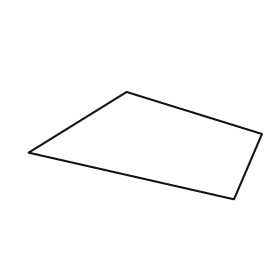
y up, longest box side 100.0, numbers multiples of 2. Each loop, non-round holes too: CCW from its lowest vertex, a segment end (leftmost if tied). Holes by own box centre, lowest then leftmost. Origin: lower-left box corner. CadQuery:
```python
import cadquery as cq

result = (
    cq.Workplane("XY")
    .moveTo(88.0, 0.0)
    .lineTo(100.0, 28.0)
    .lineTo(42.0, 46.0)
    .lineTo(0.0, 20.0)
    .close()
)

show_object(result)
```